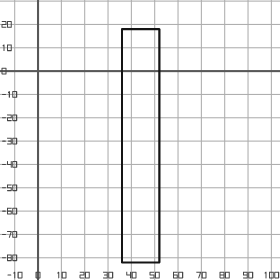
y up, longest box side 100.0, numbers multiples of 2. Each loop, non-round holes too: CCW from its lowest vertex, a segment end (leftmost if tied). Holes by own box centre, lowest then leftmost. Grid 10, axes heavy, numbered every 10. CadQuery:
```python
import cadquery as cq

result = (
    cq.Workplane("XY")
    .moveTo(36.0, -82.0)
    .lineTo(52.0, -82.0)
    .lineTo(52.0, 18.0)
    .lineTo(36.0, 18.0)
    .close()
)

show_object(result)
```